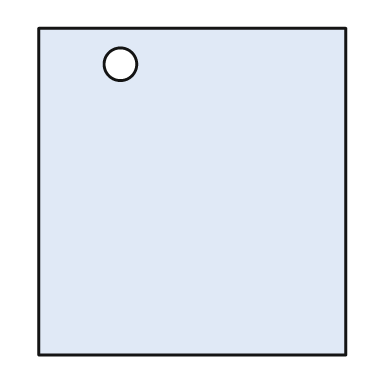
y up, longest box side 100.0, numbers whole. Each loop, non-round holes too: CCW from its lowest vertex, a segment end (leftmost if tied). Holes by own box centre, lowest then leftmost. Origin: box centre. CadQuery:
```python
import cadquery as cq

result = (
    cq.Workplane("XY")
    .moveTo(-47.0, -50.0)
    .lineTo(47.0, -50.0)
    .lineTo(47.0, 50.0)
    .lineTo(-47.0, 50.0)
    .close()
    .moveTo(-22.0, 39.0)
    .circle(5.0)
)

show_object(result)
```